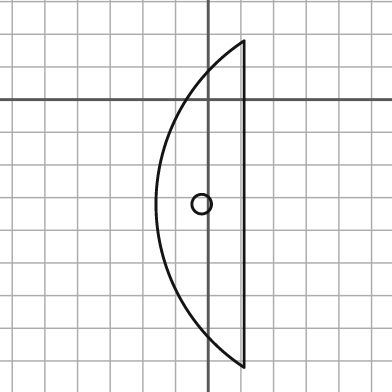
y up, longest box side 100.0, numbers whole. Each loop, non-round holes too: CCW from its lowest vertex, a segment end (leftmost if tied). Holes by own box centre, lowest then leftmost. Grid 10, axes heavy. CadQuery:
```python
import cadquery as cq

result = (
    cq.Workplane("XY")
    .moveTo(11.0, -82.0)
    .lineTo(11.0, 18.0)
    .threePointArc((-16.0, -32.0), (11.0, -82.0))
    .close()
    .moveTo(-2.0, -32.0)
    .circle(3.0)
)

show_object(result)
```